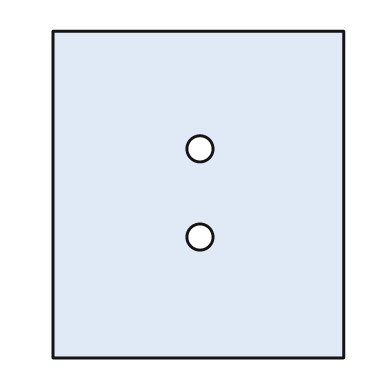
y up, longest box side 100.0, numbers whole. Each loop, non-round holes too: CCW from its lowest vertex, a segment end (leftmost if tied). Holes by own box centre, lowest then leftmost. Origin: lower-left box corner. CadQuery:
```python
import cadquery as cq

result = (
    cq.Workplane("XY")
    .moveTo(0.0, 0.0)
    .lineTo(89.0, 0.0)
    .lineTo(89.0, 100.0)
    .lineTo(0.0, 100.0)
    .close()
    .moveTo(45.0, 37.0)
    .circle(4.0)
    .moveTo(45.0, 64.0)
    .circle(4.0)
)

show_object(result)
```